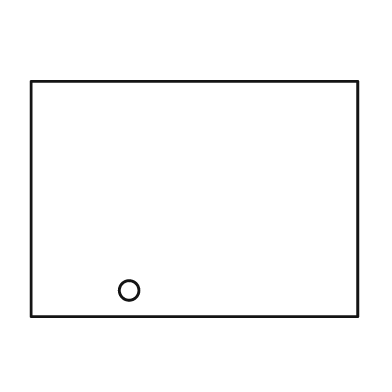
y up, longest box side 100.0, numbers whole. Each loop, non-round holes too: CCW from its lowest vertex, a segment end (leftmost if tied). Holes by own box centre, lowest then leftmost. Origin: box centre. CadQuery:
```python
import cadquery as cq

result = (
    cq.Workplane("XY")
    .moveTo(-50.0, -36.0)
    .lineTo(50.0, -36.0)
    .lineTo(50.0, 36.0)
    .lineTo(-50.0, 36.0)
    .close()
    .moveTo(-20.0, -28.0)
    .circle(3.0)
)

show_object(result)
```